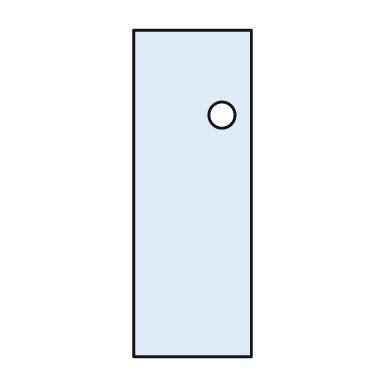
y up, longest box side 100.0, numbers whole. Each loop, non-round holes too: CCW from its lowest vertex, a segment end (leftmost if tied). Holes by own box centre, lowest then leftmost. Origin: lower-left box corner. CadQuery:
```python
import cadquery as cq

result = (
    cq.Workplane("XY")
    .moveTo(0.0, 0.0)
    .lineTo(36.0, 0.0)
    .lineTo(36.0, 100.0)
    .lineTo(0.0, 100.0)
    .close()
    .moveTo(27.0, 74.0)
    .circle(4.0)
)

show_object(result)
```